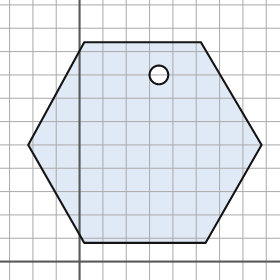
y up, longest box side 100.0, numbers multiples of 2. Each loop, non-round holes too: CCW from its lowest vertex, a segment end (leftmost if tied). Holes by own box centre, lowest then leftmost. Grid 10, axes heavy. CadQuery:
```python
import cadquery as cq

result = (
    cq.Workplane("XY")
    .moveTo(2.0, 8.0)
    .lineTo(54.0, 8.0)
    .lineTo(78.0, 50.0)
    .lineTo(52.0, 94.0)
    .lineTo(2.0, 94.0)
    .lineTo(-22.0, 50.0)
    .close()
    .moveTo(34.0, 80.0)
    .circle(4.0)
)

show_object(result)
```